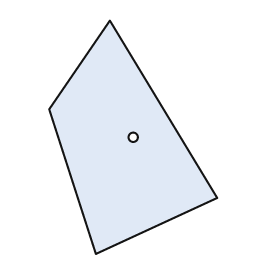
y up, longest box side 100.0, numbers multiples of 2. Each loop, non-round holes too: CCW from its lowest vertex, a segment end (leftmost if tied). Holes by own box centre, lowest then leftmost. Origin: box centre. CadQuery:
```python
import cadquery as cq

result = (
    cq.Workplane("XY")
    .moveTo(-16.0, -50.0)
    .lineTo(36.0, -26.0)
    .lineTo(-10.0, 50.0)
    .lineTo(-36.0, 12.0)
    .close()
    .moveTo(0.0, 0.0)
    .circle(2.0)
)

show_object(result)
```